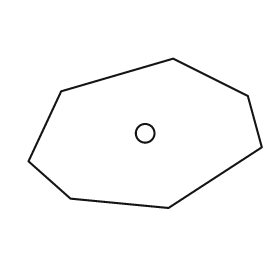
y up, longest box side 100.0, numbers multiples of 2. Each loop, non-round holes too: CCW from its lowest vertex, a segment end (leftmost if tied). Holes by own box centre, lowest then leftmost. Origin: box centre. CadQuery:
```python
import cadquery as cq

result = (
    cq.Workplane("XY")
    .moveTo(10.0, -32.0)
    .lineTo(50.0, -6.0)
    .lineTo(44.0, 16.0)
    .lineTo(12.0, 32.0)
    .lineTo(-36.0, 18.0)
    .lineTo(-50.0, -12.0)
    .lineTo(-32.0, -28.0)
    .close()
    .moveTo(0.0, 0.0)
    .circle(4.0)
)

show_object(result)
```